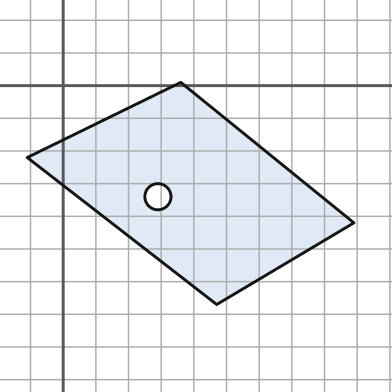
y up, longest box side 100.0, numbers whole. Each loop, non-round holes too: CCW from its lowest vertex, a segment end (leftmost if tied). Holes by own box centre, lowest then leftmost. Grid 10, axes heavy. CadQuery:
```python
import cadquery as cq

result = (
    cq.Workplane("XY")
    .moveTo(47.0, -67.0)
    .lineTo(89.0, -42.0)
    .lineTo(36.0, 1.0)
    .lineTo(-11.0, -22.0)
    .close()
    .moveTo(29.0, -34.0)
    .circle(4.0)
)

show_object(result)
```